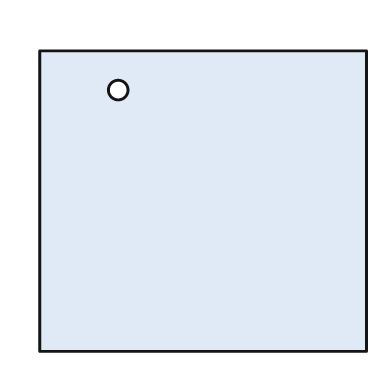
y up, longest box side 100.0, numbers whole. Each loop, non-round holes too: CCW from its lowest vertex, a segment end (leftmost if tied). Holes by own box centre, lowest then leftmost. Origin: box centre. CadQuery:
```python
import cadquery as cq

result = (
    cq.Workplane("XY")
    .moveTo(-50.0, -46.0)
    .lineTo(50.0, -46.0)
    .lineTo(50.0, 46.0)
    .lineTo(-50.0, 46.0)
    .close()
    .moveTo(-26.0, 34.0)
    .circle(3.0)
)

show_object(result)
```